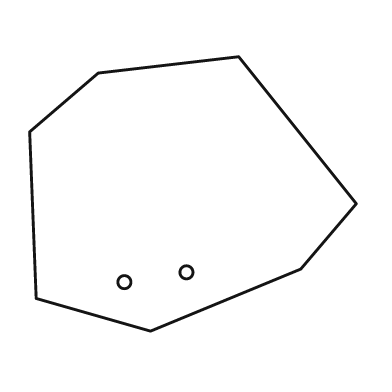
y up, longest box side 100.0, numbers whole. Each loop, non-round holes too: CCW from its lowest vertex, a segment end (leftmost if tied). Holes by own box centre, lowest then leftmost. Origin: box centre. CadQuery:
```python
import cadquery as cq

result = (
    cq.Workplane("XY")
    .moveTo(-13.0, -42.0)
    .lineTo(33.0, -23.0)
    .lineTo(50.0, -3.0)
    .lineTo(14.0, 42.0)
    .lineTo(-29.0, 37.0)
    .lineTo(-50.0, 19.0)
    .lineTo(-48.0, -32.0)
    .close()
    .moveTo(-21.0, -27.0)
    .circle(2.0)
    .moveTo(-2.0, -24.0)
    .circle(2.0)
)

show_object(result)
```